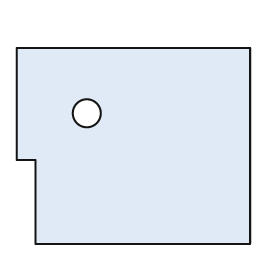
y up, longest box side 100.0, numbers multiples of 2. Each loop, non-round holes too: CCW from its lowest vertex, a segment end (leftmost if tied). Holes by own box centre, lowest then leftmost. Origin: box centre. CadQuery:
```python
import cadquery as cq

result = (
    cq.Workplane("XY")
    .moveTo(-42.0, -42.0)
    .lineTo(50.0, -42.0)
    .lineTo(50.0, 42.0)
    .lineTo(-50.0, 42.0)
    .lineTo(-50.0, -6.0)
    .lineTo(-42.0, -6.0)
    .close()
    .moveTo(-20.0, 14.0)
    .circle(6.0)
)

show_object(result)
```